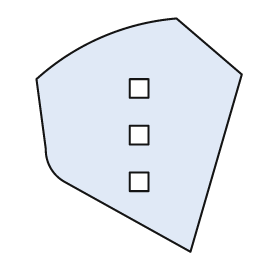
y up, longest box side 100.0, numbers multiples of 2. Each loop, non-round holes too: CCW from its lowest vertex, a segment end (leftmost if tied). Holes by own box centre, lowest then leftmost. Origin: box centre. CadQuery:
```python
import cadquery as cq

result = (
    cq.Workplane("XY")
    .moveTo(22.0, -50.0)
    .lineTo(44.0, 26.0)
    .lineTo(16.0, 50.0)
    .threePointArc((-16.0, 42.0), (-44.0, 24.0))
    .lineTo(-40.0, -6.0)
    .threePointArc((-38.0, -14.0), (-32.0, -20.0))
    .close()
    .moveTo(-4.0, -24.0)
    .lineTo(4.0, -24.0)
    .lineTo(4.0, -16.0)
    .lineTo(-4.0, -16.0)
    .close()
    .moveTo(-4.0, -4.0)
    .lineTo(4.0, -4.0)
    .lineTo(4.0, 4.0)
    .lineTo(-4.0, 4.0)
    .close()
    .moveTo(-4.0, 16.0)
    .lineTo(4.0, 16.0)
    .lineTo(4.0, 24.0)
    .lineTo(-4.0, 24.0)
    .close()
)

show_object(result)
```